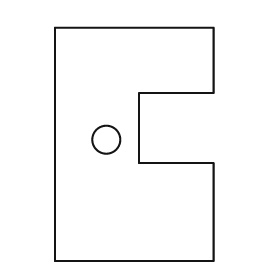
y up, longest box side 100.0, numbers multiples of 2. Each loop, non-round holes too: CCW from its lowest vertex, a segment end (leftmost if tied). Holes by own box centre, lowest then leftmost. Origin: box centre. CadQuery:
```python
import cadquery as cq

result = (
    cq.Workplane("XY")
    .moveTo(-34.0, -50.0)
    .lineTo(34.0, -50.0)
    .lineTo(34.0, -8.0)
    .lineTo(2.0, -8.0)
    .lineTo(2.0, 22.0)
    .lineTo(34.0, 22.0)
    .lineTo(34.0, 50.0)
    .lineTo(-34.0, 50.0)
    .close()
    .moveTo(-12.0, 2.0)
    .circle(6.0)
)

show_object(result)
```